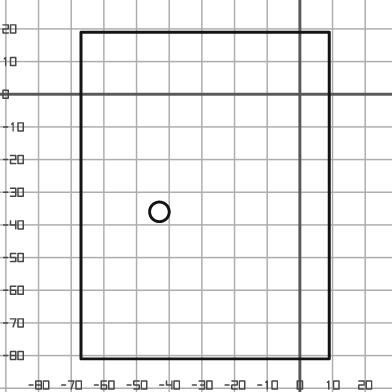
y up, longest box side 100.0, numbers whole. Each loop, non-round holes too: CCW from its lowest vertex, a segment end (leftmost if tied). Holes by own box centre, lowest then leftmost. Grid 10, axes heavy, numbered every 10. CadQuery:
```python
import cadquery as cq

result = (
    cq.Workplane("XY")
    .moveTo(-67.0, -81.0)
    .lineTo(9.0, -81.0)
    .lineTo(9.0, 19.0)
    .lineTo(-67.0, 19.0)
    .close()
    .moveTo(-43.0, -36.0)
    .circle(3.0)
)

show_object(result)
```